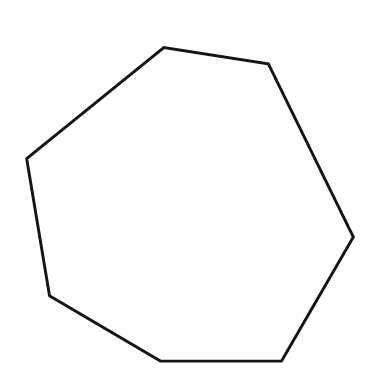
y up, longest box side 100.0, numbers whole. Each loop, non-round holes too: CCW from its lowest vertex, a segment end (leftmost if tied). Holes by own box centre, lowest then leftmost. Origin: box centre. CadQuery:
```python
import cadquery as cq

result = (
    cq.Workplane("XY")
    .moveTo(-9.0, -48.0)
    .lineTo(28.0, -48.0)
    .lineTo(50.0, -10.0)
    .lineTo(24.0, 43.0)
    .lineTo(-8.0, 48.0)
    .lineTo(-50.0, 14.0)
    .lineTo(-43.0, -28.0)
    .close()
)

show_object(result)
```